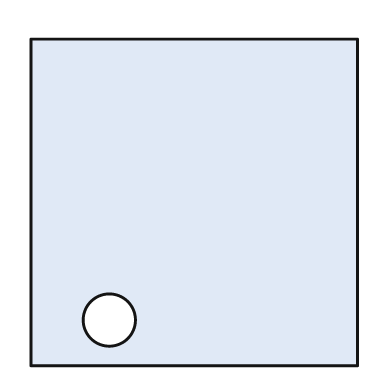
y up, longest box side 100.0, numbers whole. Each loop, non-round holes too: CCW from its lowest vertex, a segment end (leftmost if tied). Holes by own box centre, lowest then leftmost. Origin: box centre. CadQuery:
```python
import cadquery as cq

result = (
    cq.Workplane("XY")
    .moveTo(-50.0, -50.0)
    .lineTo(50.0, -50.0)
    .lineTo(50.0, 50.0)
    .lineTo(-50.0, 50.0)
    .close()
    .moveTo(-26.0, -36.0)
    .circle(8.0)
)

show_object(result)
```